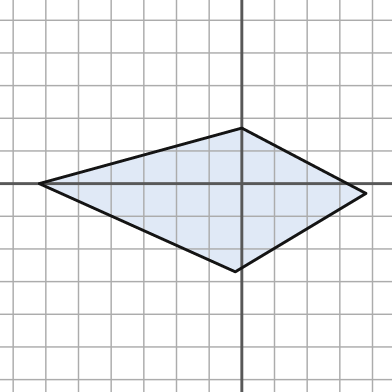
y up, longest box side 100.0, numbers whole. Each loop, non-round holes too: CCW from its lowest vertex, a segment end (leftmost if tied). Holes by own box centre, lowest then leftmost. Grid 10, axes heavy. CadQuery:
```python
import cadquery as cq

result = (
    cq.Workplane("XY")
    .moveTo(-2.0, -27.0)
    .lineTo(38.0, -3.0)
    .lineTo(0.0, 17.0)
    .lineTo(-62.0, 0.0)
    .close()
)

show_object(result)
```